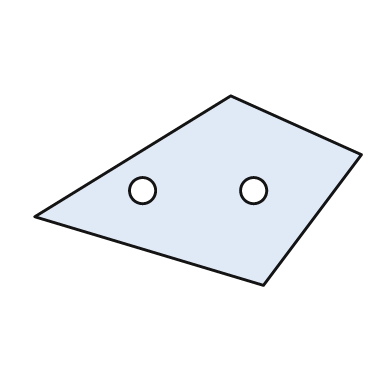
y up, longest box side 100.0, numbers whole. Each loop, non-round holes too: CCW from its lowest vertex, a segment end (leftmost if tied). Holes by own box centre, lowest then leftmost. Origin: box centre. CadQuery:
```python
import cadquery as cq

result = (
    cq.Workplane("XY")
    .moveTo(20.0, -29.0)
    .lineTo(50.0, 11.0)
    .lineTo(10.0, 29.0)
    .lineTo(-50.0, -8.0)
    .close()
    .moveTo(-17.0, 0.0)
    .circle(4.0)
    .moveTo(17.0, 0.0)
    .circle(4.0)
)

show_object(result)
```